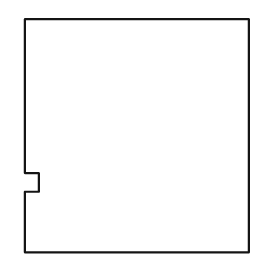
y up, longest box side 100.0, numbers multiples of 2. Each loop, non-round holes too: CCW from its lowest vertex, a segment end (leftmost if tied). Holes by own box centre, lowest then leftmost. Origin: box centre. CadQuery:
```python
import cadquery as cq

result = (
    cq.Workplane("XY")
    .moveTo(-48.0, -50.0)
    .lineTo(48.0, -50.0)
    .lineTo(48.0, 50.0)
    .lineTo(-48.0, 50.0)
    .lineTo(-48.0, -16.0)
    .lineTo(-42.0, -16.0)
    .lineTo(-42.0, -24.0)
    .lineTo(-48.0, -24.0)
    .close()
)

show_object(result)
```